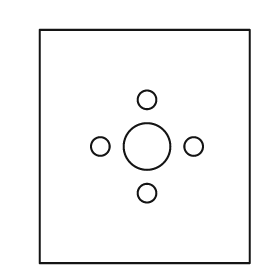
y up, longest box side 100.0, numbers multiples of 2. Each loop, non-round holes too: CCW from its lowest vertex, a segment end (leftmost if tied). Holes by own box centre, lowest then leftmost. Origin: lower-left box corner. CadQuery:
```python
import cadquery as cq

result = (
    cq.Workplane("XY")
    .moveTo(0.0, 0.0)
    .lineTo(90.0, 0.0)
    .lineTo(90.0, 100.0)
    .lineTo(0.0, 100.0)
    .close()
    .moveTo(46.0, 30.0)
    .circle(4.0)
    .moveTo(26.0, 50.0)
    .circle(4.0)
    .moveTo(46.0, 50.0)
    .circle(10.0)
    .moveTo(66.0, 50.0)
    .circle(4.0)
    .moveTo(46.0, 70.0)
    .circle(4.0)
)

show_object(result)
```